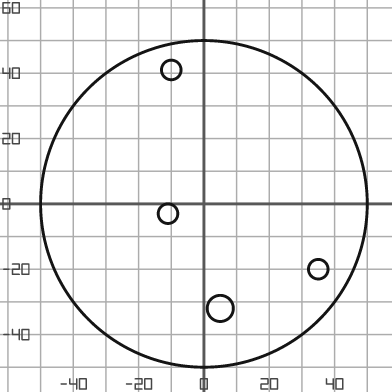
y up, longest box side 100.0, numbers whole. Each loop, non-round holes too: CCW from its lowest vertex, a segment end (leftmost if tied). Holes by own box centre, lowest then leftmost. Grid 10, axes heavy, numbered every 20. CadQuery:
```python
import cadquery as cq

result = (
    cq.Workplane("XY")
    .moveTo(0.0, 0.0)
    .circle(50.0)
    .moveTo(5.0, -32.0)
    .circle(4.0)
    .moveTo(35.0, -20.0)
    .circle(3.0)
    .moveTo(-11.0, -3.0)
    .circle(3.0)
    .moveTo(-10.0, 41.0)
    .circle(3.0)
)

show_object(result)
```